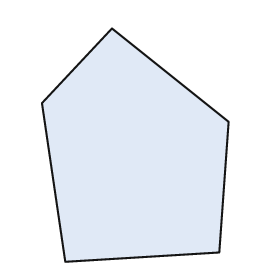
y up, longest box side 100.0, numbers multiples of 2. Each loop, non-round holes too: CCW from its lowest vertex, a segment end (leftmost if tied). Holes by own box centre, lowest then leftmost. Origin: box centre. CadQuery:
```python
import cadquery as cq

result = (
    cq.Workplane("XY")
    .moveTo(-30.0, -50.0)
    .lineTo(36.0, -46.0)
    .lineTo(40.0, 10.0)
    .lineTo(-10.0, 50.0)
    .lineTo(-40.0, 18.0)
    .close()
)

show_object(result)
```